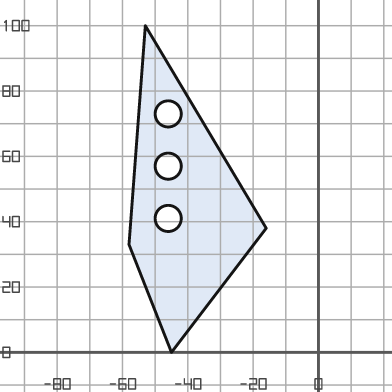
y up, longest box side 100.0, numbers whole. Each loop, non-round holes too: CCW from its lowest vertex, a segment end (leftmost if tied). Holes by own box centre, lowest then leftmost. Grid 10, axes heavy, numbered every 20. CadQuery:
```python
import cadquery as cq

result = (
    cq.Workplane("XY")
    .moveTo(-45.0, 0.0)
    .lineTo(-16.0, 38.0)
    .lineTo(-53.0, 100.0)
    .lineTo(-58.0, 33.0)
    .close()
    .moveTo(-46.0, 41.0)
    .circle(4.0)
    .moveTo(-46.0, 57.0)
    .circle(4.0)
    .moveTo(-46.0, 73.0)
    .circle(4.0)
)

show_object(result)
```